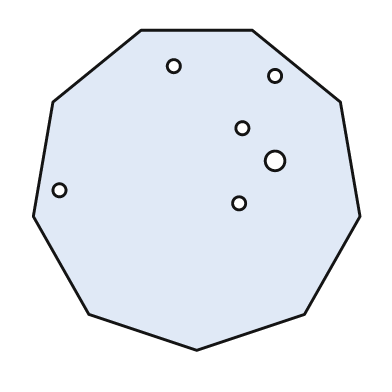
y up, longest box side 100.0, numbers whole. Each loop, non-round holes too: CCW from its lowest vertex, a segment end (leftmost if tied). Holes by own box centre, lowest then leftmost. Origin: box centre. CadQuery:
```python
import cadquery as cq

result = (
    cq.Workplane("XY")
    .moveTo(0.0, -49.0)
    .lineTo(33.0, -38.0)
    .lineTo(50.0, -8.0)
    .lineTo(44.0, 27.0)
    .lineTo(17.0, 49.0)
    .lineTo(-17.0, 49.0)
    .lineTo(-44.0, 27.0)
    .lineTo(-50.0, -8.0)
    .lineTo(-33.0, -38.0)
    .close()
    .moveTo(13.0, -4.0)
    .circle(2.0)
    .moveTo(-42.0, 0.0)
    .circle(2.0)
    .moveTo(24.0, 9.0)
    .circle(3.0)
    .moveTo(14.0, 19.0)
    .circle(2.0)
    .moveTo(24.0, 35.0)
    .circle(2.0)
    .moveTo(-7.0, 38.0)
    .circle(2.0)
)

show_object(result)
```